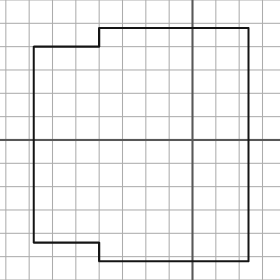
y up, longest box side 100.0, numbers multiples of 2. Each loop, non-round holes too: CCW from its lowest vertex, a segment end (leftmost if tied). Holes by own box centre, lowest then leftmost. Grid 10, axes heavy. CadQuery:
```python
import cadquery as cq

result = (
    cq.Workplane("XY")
    .moveTo(-40.0, -52.0)
    .lineTo(24.0, -52.0)
    .lineTo(24.0, 48.0)
    .lineTo(-40.0, 48.0)
    .lineTo(-40.0, 40.0)
    .lineTo(-68.0, 40.0)
    .lineTo(-68.0, -44.0)
    .lineTo(-40.0, -44.0)
    .close()
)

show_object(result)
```